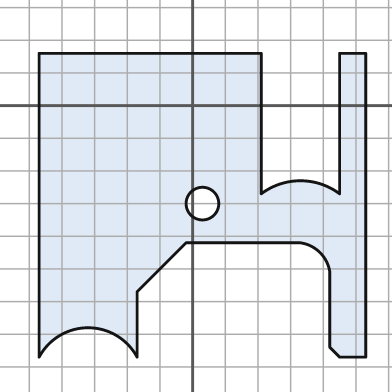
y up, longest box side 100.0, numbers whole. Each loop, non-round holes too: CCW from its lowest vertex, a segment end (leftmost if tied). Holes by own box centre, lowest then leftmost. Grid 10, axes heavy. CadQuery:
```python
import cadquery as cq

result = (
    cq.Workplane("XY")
    .moveTo(-47.0, -77.0)
    .threePointArc((-32.0, -68.0), (-17.0, -77.0))
    .lineTo(-17.0, -57.0)
    .lineTo(-2.0, -42.0)
    .lineTo(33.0, -42.0)
    .threePointArc((39.0, -45.0), (42.0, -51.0))
    .lineTo(42.0, -74.0)
    .lineTo(45.0, -77.0)
    .lineTo(53.0, -77.0)
    .lineTo(53.0, 16.0)
    .lineTo(45.0, 16.0)
    .lineTo(45.0, -27.0)
    .threePointArc((33.0, -23.0), (21.0, -27.0))
    .lineTo(21.0, 16.0)
    .lineTo(-47.0, 16.0)
    .close()
    .moveTo(3.0, -30.0)
    .circle(5.0)
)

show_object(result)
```